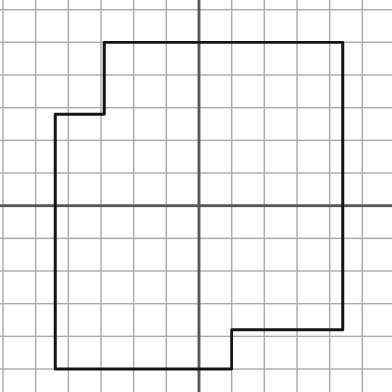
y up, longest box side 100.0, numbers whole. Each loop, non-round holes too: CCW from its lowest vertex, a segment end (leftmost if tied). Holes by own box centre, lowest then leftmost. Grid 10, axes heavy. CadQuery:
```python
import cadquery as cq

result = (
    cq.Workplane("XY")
    .moveTo(-44.0, -50.0)
    .lineTo(10.0, -50.0)
    .lineTo(10.0, -38.0)
    .lineTo(44.0, -38.0)
    .lineTo(44.0, 50.0)
    .lineTo(-29.0, 50.0)
    .lineTo(-29.0, 28.0)
    .lineTo(-44.0, 28.0)
    .close()
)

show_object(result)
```